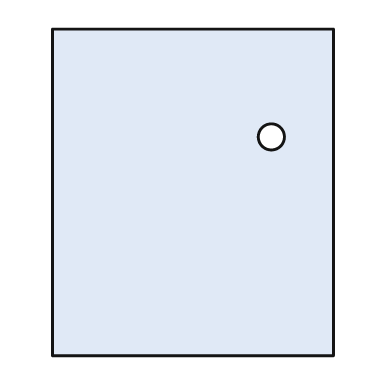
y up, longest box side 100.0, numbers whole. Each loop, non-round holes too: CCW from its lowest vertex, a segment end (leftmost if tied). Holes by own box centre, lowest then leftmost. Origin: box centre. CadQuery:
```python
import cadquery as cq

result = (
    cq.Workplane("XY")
    .moveTo(-43.0, -50.0)
    .lineTo(43.0, -50.0)
    .lineTo(43.0, 50.0)
    .lineTo(-43.0, 50.0)
    .close()
    .moveTo(24.0, 17.0)
    .circle(4.0)
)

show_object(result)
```